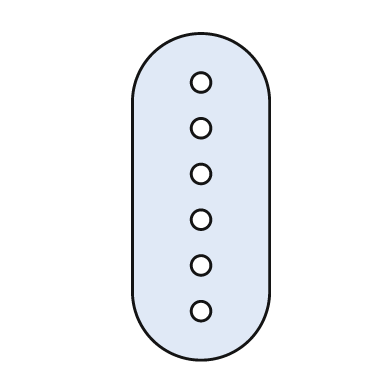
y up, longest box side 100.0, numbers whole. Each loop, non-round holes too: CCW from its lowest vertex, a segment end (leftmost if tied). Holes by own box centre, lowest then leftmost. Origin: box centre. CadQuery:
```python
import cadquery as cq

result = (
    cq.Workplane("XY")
    .moveTo(-21.0, -29.0)
    .threePointArc((0.0, -50.0), (21.0, -29.0))
    .lineTo(21.0, 29.0)
    .threePointArc((0.0, 50.0), (-21.0, 29.0))
    .close()
    .moveTo(0.0, -35.0)
    .circle(3.0)
    .moveTo(0.0, -21.0)
    .circle(3.0)
    .moveTo(0.0, -7.0)
    .circle(3.0)
    .moveTo(0.0, 7.0)
    .circle(3.0)
    .moveTo(0.0, 21.0)
    .circle(3.0)
    .moveTo(0.0, 35.0)
    .circle(3.0)
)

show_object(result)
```